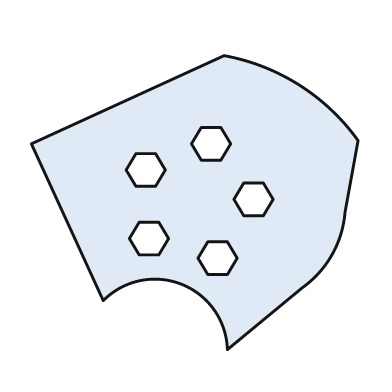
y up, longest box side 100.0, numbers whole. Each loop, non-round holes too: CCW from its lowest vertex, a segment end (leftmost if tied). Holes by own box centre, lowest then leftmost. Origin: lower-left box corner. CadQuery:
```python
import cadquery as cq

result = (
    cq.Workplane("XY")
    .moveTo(60.0, 0.0)
    .lineTo(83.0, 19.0)
    .threePointArc((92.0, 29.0), (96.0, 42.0))
    .lineTo(100.0, 64.0)
    .threePointArc((82.0, 81.0), (59.0, 90.0))
    .lineTo(0.0, 63.0)
    .lineTo(22.0, 15.0)
    .threePointArc((46.0, 20.0), (60.0, 0.0))
    .close()
    .moveTo(54.0, 23.0)
    .lineTo(60.0, 23.0)
    .lineTo(63.0, 28.0)
    .lineTo(60.0, 33.0)
    .lineTo(54.0, 33.0)
    .lineTo(51.0, 28.0)
    .close()
    .moveTo(33.0, 29.0)
    .lineTo(39.0, 29.0)
    .lineTo(42.0, 34.0)
    .lineTo(39.0, 39.0)
    .lineTo(33.0, 39.0)
    .lineTo(30.0, 34.0)
    .close()
    .moveTo(65.0, 41.0)
    .lineTo(71.0, 41.0)
    .lineTo(74.0, 46.0)
    .lineTo(71.0, 51.0)
    .lineTo(65.0, 51.0)
    .lineTo(62.0, 46.0)
    .close()
    .moveTo(32.0, 50.0)
    .lineTo(38.0, 50.0)
    .lineTo(41.0, 55.0)
    .lineTo(38.0, 60.0)
    .lineTo(32.0, 60.0)
    .lineTo(29.0, 55.0)
    .close()
    .moveTo(52.0, 58.0)
    .lineTo(58.0, 58.0)
    .lineTo(61.0, 63.0)
    .lineTo(58.0, 68.0)
    .lineTo(52.0, 68.0)
    .lineTo(49.0, 63.0)
    .close()
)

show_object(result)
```